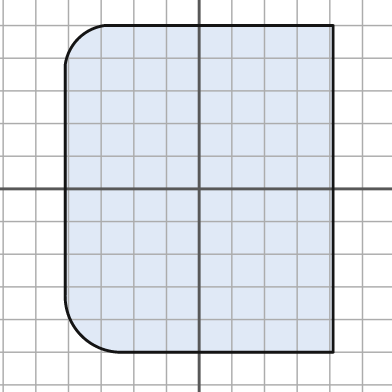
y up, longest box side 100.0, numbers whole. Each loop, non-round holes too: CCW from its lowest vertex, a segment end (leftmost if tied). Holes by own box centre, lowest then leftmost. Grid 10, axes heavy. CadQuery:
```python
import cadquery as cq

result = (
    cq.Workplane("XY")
    .moveTo(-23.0, -50.0)
    .lineTo(41.0, -50.0)
    .lineTo(41.0, 50.0)
    .lineTo(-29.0, 50.0)
    .threePointArc((-37.0, 46.0), (-41.0, 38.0))
    .lineTo(-41.0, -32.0)
    .threePointArc((-36.0, -45.0), (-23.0, -50.0))
    .close()
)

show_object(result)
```